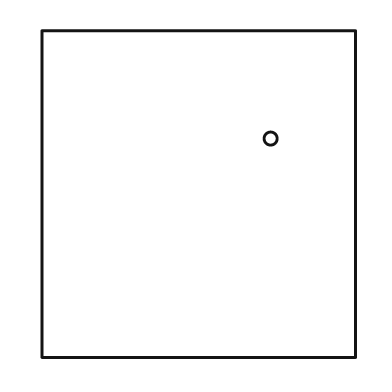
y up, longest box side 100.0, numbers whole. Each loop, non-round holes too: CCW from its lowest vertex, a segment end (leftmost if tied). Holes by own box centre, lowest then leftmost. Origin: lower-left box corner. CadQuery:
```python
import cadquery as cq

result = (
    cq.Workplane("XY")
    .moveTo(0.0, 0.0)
    .lineTo(96.0, 0.0)
    .lineTo(96.0, 100.0)
    .lineTo(0.0, 100.0)
    .close()
    .moveTo(70.0, 67.0)
    .circle(2.0)
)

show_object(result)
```